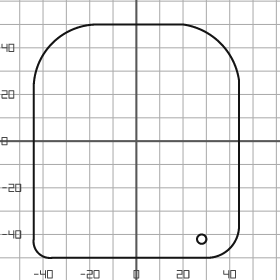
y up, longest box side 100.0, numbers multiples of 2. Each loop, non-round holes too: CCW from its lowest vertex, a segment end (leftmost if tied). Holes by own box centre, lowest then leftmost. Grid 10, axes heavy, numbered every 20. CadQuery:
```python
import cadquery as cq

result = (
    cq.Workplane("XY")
    .moveTo(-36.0, -50.0)
    .lineTo(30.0, -50.0)
    .threePointArc((40.0, -46.0), (44.0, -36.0))
    .lineTo(44.0, 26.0)
    .threePointArc((36.0, 42.0), (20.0, 50.0))
    .lineTo(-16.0, 50.0)
    .threePointArc((-36.0, 42.0), (-44.0, 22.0))
    .lineTo(-44.0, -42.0)
    .threePointArc((-42.0, -48.0), (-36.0, -50.0))
    .close()
    .moveTo(28.0, -42.0)
    .circle(2.0)
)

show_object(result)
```